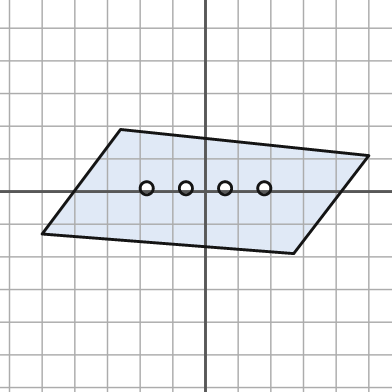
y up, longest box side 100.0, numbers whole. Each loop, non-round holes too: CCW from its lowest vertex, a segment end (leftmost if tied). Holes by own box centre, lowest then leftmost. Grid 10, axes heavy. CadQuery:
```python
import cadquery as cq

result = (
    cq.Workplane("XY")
    .moveTo(27.0, -19.0)
    .lineTo(50.0, 11.0)
    .lineTo(-26.0, 19.0)
    .lineTo(-50.0, -13.0)
    .close()
    .moveTo(-18.0, 1.0)
    .circle(2.0)
    .moveTo(-6.0, 1.0)
    .circle(2.0)
    .moveTo(6.0, 1.0)
    .circle(2.0)
    .moveTo(18.0, 1.0)
    .circle(2.0)
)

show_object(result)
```